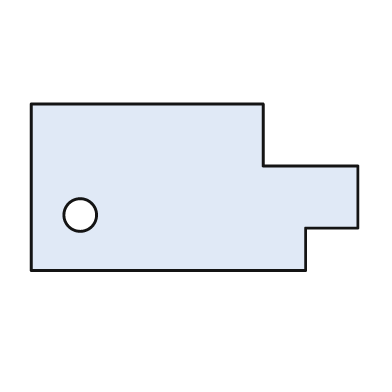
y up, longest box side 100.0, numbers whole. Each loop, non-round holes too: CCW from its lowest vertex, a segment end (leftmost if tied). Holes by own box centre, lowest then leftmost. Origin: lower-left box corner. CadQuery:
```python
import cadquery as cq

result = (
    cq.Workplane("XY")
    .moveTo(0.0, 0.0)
    .lineTo(84.0, 0.0)
    .lineTo(84.0, 13.0)
    .lineTo(100.0, 13.0)
    .lineTo(100.0, 32.0)
    .lineTo(71.0, 32.0)
    .lineTo(71.0, 51.0)
    .lineTo(0.0, 51.0)
    .close()
    .moveTo(15.0, 17.0)
    .circle(5.0)
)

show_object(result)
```